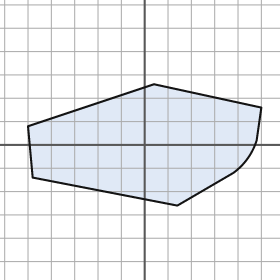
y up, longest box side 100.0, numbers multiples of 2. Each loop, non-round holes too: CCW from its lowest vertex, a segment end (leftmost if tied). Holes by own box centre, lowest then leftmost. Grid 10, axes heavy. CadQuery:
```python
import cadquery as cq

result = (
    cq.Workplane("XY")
    .moveTo(14.0, -26.0)
    .lineTo(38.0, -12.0)
    .threePointArc((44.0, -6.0), (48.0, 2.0))
    .lineTo(50.0, 16.0)
    .lineTo(4.0, 26.0)
    .lineTo(-50.0, 8.0)
    .lineTo(-48.0, -14.0)
    .close()
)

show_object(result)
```